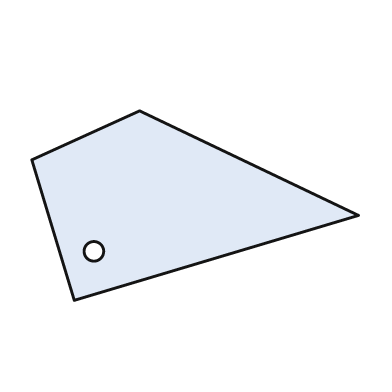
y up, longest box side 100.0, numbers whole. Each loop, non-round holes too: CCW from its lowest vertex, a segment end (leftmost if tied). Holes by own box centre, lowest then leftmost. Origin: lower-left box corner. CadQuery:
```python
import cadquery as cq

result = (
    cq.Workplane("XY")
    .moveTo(13.0, 0.0)
    .lineTo(100.0, 26.0)
    .lineTo(33.0, 58.0)
    .lineTo(0.0, 43.0)
    .close()
    .moveTo(19.0, 15.0)
    .circle(3.0)
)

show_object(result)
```